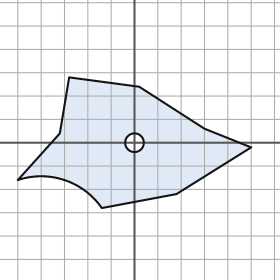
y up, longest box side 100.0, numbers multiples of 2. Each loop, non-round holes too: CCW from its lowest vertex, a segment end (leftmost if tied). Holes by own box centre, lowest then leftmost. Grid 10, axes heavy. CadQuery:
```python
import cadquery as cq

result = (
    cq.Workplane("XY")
    .moveTo(-14.0, -28.0)
    .lineTo(18.0, -22.0)
    .lineTo(50.0, -2.0)
    .lineTo(30.0, 6.0)
    .lineTo(2.0, 24.0)
    .lineTo(-28.0, 28.0)
    .lineTo(-32.0, 4.0)
    .lineTo(-50.0, -16.0)
    .threePointArc((-30.0, -16.0), (-14.0, -28.0))
    .close()
    .moveTo(0.0, 0.0)
    .circle(4.0)
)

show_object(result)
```